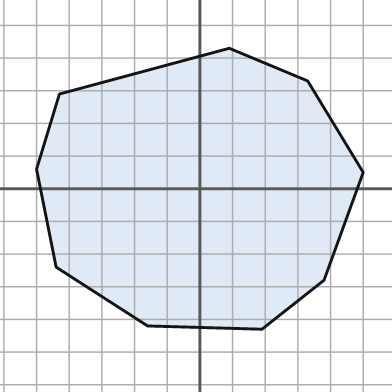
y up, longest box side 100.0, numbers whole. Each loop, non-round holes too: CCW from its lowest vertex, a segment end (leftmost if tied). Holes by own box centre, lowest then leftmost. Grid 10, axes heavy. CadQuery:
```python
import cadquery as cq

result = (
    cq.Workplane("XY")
    .moveTo(19.0, -43.0)
    .lineTo(38.0, -28.0)
    .lineTo(50.0, 5.0)
    .lineTo(33.0, 33.0)
    .lineTo(9.0, 43.0)
    .lineTo(-43.0, 29.0)
    .lineTo(-50.0, 6.0)
    .lineTo(-44.0, -24.0)
    .lineTo(-16.0, -42.0)
    .close()
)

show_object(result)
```